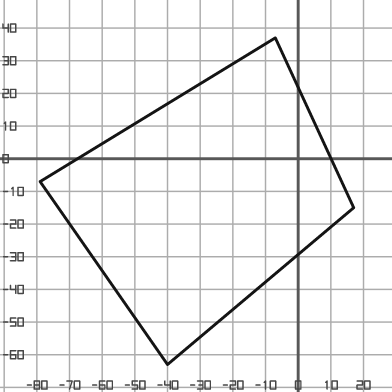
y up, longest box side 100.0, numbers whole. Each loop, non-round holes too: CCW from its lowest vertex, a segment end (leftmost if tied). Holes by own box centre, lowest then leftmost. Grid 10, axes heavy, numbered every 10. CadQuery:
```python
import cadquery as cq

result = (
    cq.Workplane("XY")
    .moveTo(-40.0, -63.0)
    .lineTo(17.0, -15.0)
    .lineTo(-7.0, 37.0)
    .lineTo(-79.0, -7.0)
    .close()
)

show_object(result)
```